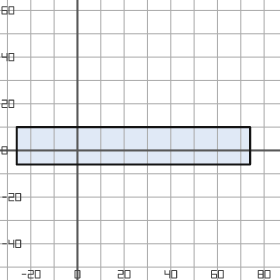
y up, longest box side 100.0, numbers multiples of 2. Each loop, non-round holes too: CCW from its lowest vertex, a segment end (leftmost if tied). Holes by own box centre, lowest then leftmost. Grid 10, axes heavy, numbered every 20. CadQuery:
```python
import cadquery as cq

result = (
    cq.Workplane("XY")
    .moveTo(-26.0, -6.0)
    .lineTo(74.0, -6.0)
    .lineTo(74.0, 10.0)
    .lineTo(-26.0, 10.0)
    .close()
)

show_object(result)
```